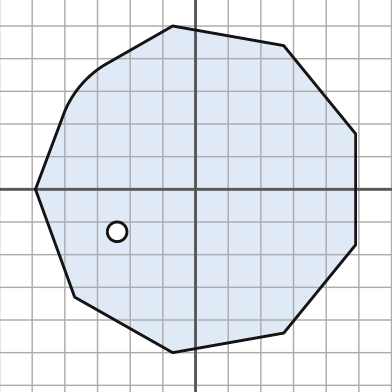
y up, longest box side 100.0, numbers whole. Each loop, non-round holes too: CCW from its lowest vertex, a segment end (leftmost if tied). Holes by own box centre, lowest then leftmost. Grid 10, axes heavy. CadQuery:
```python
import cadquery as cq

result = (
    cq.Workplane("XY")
    .moveTo(-7.0, -50.0)
    .lineTo(27.0, -44.0)
    .lineTo(49.0, -17.0)
    .lineTo(49.0, 17.0)
    .lineTo(27.0, 44.0)
    .lineTo(-7.0, 50.0)
    .lineTo(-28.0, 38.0)
    .threePointArc((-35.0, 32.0), (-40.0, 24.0))
    .lineTo(-49.0, 0.0)
    .lineTo(-37.0, -33.0)
    .close()
    .moveTo(-24.0, -13.0)
    .circle(3.0)
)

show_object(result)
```